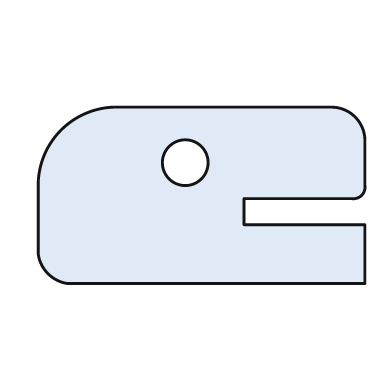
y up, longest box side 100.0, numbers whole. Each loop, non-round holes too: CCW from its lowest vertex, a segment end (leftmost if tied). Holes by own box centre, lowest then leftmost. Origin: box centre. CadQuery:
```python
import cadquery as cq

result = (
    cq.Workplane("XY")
    .moveTo(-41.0, -27.0)
    .lineTo(50.0, -27.0)
    .lineTo(50.0, -9.0)
    .lineTo(13.0, -9.0)
    .lineTo(13.0, -1.0)
    .lineTo(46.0, -1.0)
    .threePointArc((49.0, 0.0), (50.0, 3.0))
    .lineTo(50.0, 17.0)
    .threePointArc((47.0, 24.0), (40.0, 27.0))
    .lineTo(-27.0, 27.0)
    .threePointArc((-43.0, 20.0), (-50.0, 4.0))
    .lineTo(-50.0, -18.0)
    .threePointArc((-47.0, -24.0), (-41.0, -27.0))
    .close()
    .moveTo(-5.0, 10.0)
    .circle(7.0)
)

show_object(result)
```